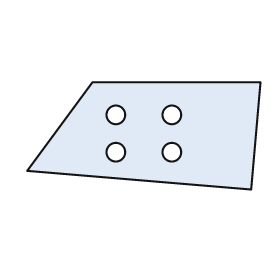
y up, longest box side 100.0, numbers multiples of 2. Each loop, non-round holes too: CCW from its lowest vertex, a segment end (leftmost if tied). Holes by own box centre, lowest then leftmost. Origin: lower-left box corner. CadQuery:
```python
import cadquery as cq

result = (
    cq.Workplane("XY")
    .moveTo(96.0, 0.0)
    .lineTo(100.0, 46.0)
    .lineTo(28.0, 46.0)
    .lineTo(0.0, 8.0)
    .close()
    .moveTo(38.0, 16.0)
    .circle(4.0)
    .moveTo(62.0, 16.0)
    .circle(4.0)
    .moveTo(38.0, 32.0)
    .circle(4.0)
    .moveTo(62.0, 32.0)
    .circle(4.0)
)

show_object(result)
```